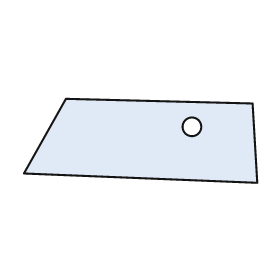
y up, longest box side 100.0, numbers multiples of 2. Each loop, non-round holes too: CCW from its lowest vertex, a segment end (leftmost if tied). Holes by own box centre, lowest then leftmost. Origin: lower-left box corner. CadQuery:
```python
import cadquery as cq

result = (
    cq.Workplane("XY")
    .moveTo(100.0, 0.0)
    .lineTo(98.0, 34.0)
    .lineTo(18.0, 36.0)
    .lineTo(0.0, 4.0)
    .close()
    .moveTo(72.0, 24.0)
    .circle(4.0)
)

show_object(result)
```